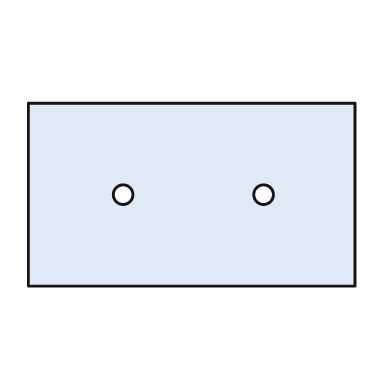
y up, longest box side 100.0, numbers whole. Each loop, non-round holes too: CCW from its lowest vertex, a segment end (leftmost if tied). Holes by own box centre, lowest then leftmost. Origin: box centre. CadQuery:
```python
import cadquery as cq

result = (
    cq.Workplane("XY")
    .moveTo(-50.0, -28.0)
    .lineTo(50.0, -28.0)
    .lineTo(50.0, 28.0)
    .lineTo(-50.0, 28.0)
    .close()
    .moveTo(-21.0, 0.0)
    .circle(3.0)
    .moveTo(22.0, 0.0)
    .circle(3.0)
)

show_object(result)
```